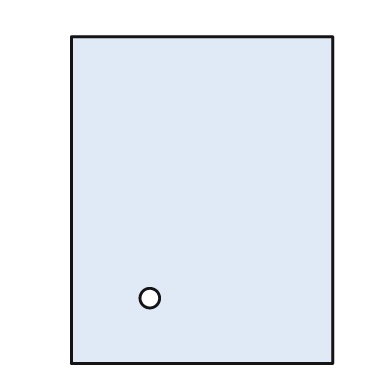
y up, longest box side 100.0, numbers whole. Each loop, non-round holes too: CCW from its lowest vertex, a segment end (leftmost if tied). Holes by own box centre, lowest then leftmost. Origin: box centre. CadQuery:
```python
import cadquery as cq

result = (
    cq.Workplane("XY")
    .moveTo(-40.0, -50.0)
    .lineTo(40.0, -50.0)
    .lineTo(40.0, 50.0)
    .lineTo(-40.0, 50.0)
    .close()
    .moveTo(-16.0, -30.0)
    .circle(3.0)
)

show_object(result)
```